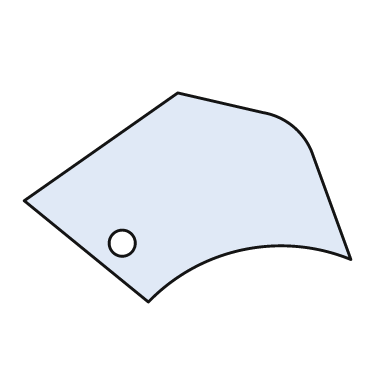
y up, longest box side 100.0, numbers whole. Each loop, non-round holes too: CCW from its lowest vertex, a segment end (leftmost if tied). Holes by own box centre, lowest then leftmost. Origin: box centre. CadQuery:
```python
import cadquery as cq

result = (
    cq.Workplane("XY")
    .moveTo(-12.0, -32.0)
    .threePointArc((17.0, -16.0), (50.0, -19.0))
    .lineTo(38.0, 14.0)
    .threePointArc((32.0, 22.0), (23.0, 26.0))
    .lineTo(-3.0, 32.0)
    .lineTo(-50.0, -1.0)
    .close()
    .moveTo(-20.0, -14.0)
    .circle(4.0)
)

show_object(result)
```